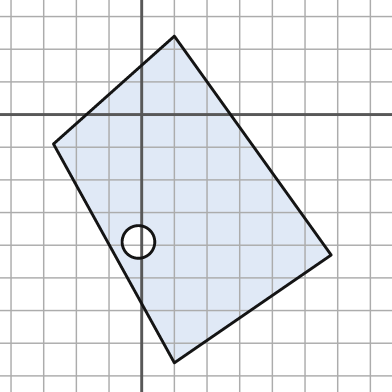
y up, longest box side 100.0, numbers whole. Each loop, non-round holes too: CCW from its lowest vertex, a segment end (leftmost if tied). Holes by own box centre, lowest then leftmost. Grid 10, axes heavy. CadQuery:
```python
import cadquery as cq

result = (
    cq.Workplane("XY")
    .moveTo(10.0, -76.0)
    .lineTo(58.0, -43.0)
    .lineTo(10.0, 24.0)
    .lineTo(-27.0, -9.0)
    .close()
    .moveTo(-1.0, -39.0)
    .circle(5.0)
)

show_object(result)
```